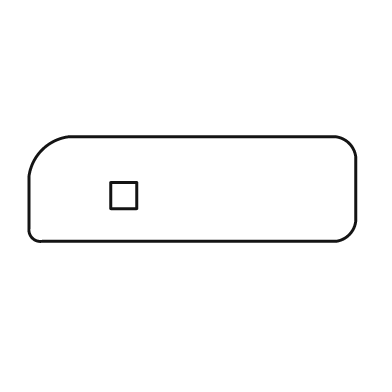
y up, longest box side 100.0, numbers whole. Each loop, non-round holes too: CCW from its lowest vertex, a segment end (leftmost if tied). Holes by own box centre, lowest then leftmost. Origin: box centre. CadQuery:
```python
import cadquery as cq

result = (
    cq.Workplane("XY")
    .moveTo(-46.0, -16.0)
    .lineTo(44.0, -16.0)
    .threePointArc((48.0, -14.0), (50.0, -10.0))
    .lineTo(50.0, 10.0)
    .threePointArc((48.0, 14.0), (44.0, 16.0))
    .lineTo(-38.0, 16.0)
    .threePointArc((-46.0, 12.0), (-50.0, 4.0))
    .lineTo(-50.0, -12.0)
    .threePointArc((-49.0, -15.0), (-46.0, -16.0))
    .close()
    .moveTo(-25.0, -6.0)
    .lineTo(-17.0, -6.0)
    .lineTo(-17.0, 2.0)
    .lineTo(-25.0, 2.0)
    .close()
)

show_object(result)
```